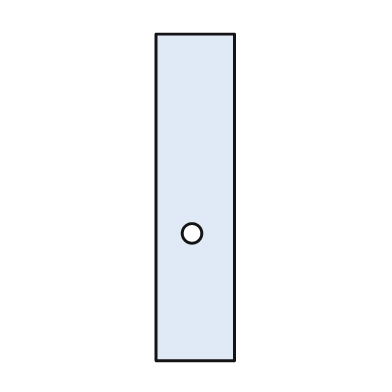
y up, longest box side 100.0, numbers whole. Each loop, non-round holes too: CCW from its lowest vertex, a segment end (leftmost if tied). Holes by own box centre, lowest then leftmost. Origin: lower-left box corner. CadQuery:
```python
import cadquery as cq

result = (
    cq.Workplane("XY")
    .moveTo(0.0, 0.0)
    .lineTo(24.0, 0.0)
    .lineTo(24.0, 100.0)
    .lineTo(0.0, 100.0)
    .close()
    .moveTo(11.0, 39.0)
    .circle(3.0)
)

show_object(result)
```